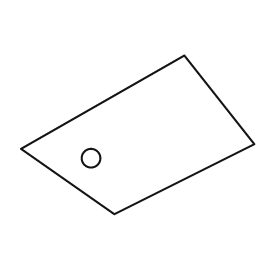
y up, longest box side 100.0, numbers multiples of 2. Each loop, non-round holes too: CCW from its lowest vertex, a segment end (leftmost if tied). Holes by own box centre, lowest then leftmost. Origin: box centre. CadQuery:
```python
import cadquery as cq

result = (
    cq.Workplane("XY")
    .moveTo(-10.0, -34.0)
    .lineTo(50.0, -4.0)
    .lineTo(20.0, 34.0)
    .lineTo(-50.0, -6.0)
    .close()
    .moveTo(-20.0, -10.0)
    .circle(4.0)
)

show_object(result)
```